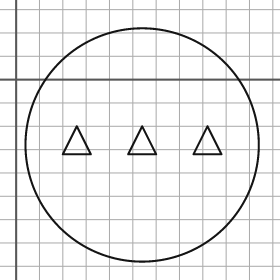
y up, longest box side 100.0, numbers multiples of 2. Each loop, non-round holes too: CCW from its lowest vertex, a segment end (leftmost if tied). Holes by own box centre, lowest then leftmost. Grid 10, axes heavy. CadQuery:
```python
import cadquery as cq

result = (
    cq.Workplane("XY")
    .moveTo(54.0, -28.0)
    .circle(50.0)
    .moveTo(20.0, -32.0)
    .lineTo(32.0, -32.0)
    .lineTo(26.0, -20.0)
    .close()
    .moveTo(48.0, -32.0)
    .lineTo(60.0, -32.0)
    .lineTo(54.0, -20.0)
    .close()
    .moveTo(76.0, -32.0)
    .lineTo(88.0, -32.0)
    .lineTo(82.0, -20.0)
    .close()
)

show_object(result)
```